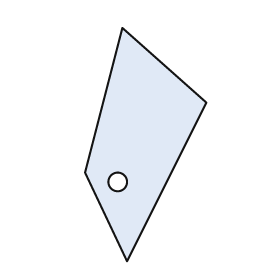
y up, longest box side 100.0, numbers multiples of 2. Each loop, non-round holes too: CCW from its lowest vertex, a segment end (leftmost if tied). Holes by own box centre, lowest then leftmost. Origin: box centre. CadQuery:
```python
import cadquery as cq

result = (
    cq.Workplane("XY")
    .moveTo(-8.0, -50.0)
    .lineTo(26.0, 18.0)
    .lineTo(-10.0, 50.0)
    .lineTo(-26.0, -12.0)
    .close()
    .moveTo(-12.0, -16.0)
    .circle(4.0)
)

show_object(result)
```